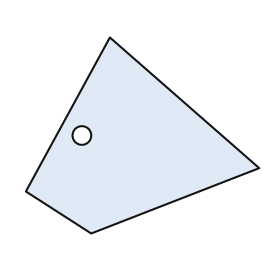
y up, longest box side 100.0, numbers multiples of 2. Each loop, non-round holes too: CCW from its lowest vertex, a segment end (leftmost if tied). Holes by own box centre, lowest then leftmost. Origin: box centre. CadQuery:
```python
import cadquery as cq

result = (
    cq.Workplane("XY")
    .moveTo(-22.0, -42.0)
    .lineTo(50.0, -14.0)
    .lineTo(-14.0, 42.0)
    .lineTo(-50.0, -24.0)
    .close()
    .moveTo(-26.0, 0.0)
    .circle(4.0)
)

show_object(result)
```